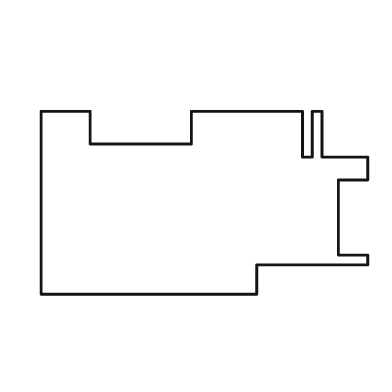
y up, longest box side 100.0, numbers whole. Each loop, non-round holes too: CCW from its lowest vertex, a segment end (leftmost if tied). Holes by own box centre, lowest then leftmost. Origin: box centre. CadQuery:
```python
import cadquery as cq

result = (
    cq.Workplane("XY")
    .moveTo(-50.0, -28.0)
    .lineTo(16.0, -28.0)
    .lineTo(16.0, -19.0)
    .lineTo(50.0, -19.0)
    .lineTo(50.0, -16.0)
    .lineTo(41.0, -16.0)
    .lineTo(41.0, 7.0)
    .lineTo(50.0, 7.0)
    .lineTo(50.0, 14.0)
    .lineTo(36.0, 14.0)
    .lineTo(36.0, 28.0)
    .lineTo(33.0, 28.0)
    .lineTo(33.0, 14.0)
    .lineTo(30.0, 14.0)
    .lineTo(30.0, 28.0)
    .lineTo(-4.0, 28.0)
    .lineTo(-4.0, 18.0)
    .lineTo(-35.0, 18.0)
    .lineTo(-35.0, 28.0)
    .lineTo(-50.0, 28.0)
    .close()
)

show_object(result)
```